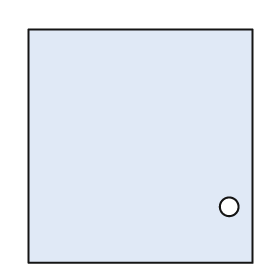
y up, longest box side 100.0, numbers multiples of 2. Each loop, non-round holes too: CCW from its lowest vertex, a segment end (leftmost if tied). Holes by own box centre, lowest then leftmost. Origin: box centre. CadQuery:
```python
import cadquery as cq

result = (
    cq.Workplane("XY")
    .moveTo(-48.0, -50.0)
    .lineTo(48.0, -50.0)
    .lineTo(48.0, 50.0)
    .lineTo(-48.0, 50.0)
    .close()
    .moveTo(38.0, -26.0)
    .circle(4.0)
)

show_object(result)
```